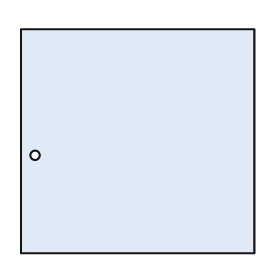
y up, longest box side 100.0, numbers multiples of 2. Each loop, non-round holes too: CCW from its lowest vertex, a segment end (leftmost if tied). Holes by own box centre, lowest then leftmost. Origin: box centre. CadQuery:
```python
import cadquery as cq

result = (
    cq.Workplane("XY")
    .moveTo(-50.0, -48.0)
    .lineTo(50.0, -48.0)
    .lineTo(50.0, 48.0)
    .lineTo(-50.0, 48.0)
    .close()
    .moveTo(-44.0, -6.0)
    .circle(2.0)
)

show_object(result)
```